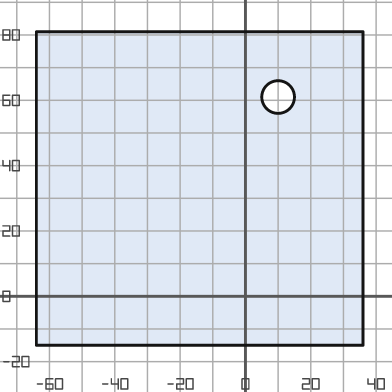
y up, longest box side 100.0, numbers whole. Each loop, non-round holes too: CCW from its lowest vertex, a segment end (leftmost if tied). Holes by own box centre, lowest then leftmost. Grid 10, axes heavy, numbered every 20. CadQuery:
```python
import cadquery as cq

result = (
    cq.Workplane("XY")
    .moveTo(-64.0, -15.0)
    .lineTo(36.0, -15.0)
    .lineTo(36.0, 81.0)
    .lineTo(-64.0, 81.0)
    .close()
    .moveTo(10.0, 61.0)
    .circle(5.0)
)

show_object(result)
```